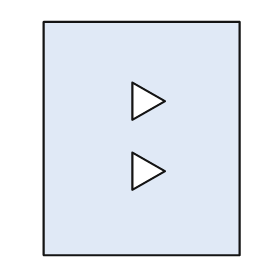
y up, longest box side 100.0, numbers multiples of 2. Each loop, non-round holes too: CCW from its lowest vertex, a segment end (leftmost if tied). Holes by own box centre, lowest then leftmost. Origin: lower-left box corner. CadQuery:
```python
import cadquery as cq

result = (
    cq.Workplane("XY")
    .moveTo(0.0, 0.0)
    .lineTo(84.0, 0.0)
    .lineTo(84.0, 100.0)
    .lineTo(0.0, 100.0)
    .close()
    .moveTo(38.0, 28.0)
    .lineTo(52.0, 36.0)
    .lineTo(38.0, 44.0)
    .close()
    .moveTo(38.0, 58.0)
    .lineTo(52.0, 66.0)
    .lineTo(38.0, 74.0)
    .close()
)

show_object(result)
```